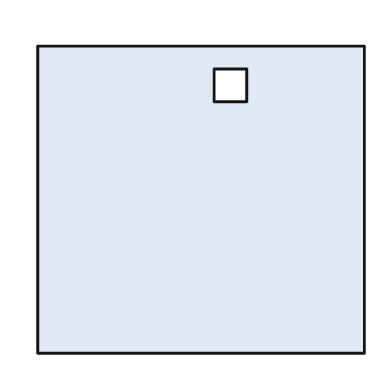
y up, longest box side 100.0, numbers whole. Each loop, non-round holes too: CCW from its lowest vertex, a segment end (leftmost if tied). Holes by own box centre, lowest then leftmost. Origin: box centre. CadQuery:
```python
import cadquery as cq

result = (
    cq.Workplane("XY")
    .moveTo(-50.0, -47.0)
    .lineTo(50.0, -47.0)
    .lineTo(50.0, 47.0)
    .lineTo(-50.0, 47.0)
    .close()
    .moveTo(4.0, 30.0)
    .lineTo(14.0, 30.0)
    .lineTo(14.0, 40.0)
    .lineTo(4.0, 40.0)
    .close()
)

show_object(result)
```